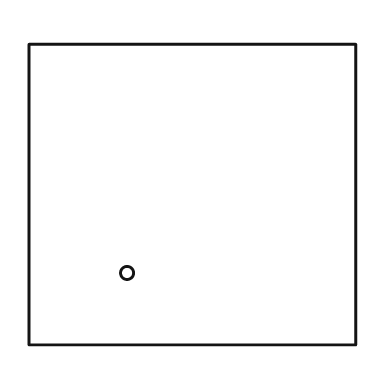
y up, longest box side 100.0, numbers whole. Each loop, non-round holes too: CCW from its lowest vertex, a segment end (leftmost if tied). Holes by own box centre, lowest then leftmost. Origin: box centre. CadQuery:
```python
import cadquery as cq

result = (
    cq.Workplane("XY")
    .moveTo(-50.0, -46.0)
    .lineTo(50.0, -46.0)
    .lineTo(50.0, 46.0)
    .lineTo(-50.0, 46.0)
    .close()
    .moveTo(-20.0, -24.0)
    .circle(2.0)
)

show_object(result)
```